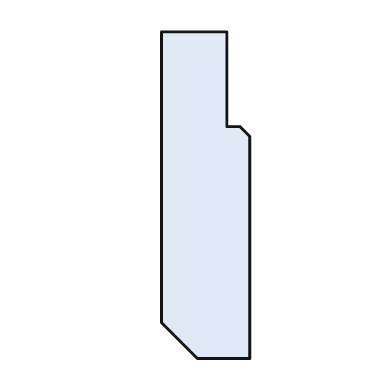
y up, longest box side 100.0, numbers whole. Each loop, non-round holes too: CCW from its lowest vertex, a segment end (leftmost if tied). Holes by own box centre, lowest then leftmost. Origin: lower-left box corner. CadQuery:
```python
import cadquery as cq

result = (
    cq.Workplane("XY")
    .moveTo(11.0, 0.0)
    .lineTo(27.0, 0.0)
    .lineTo(27.0, 68.0)
    .lineTo(24.0, 71.0)
    .lineTo(20.0, 71.0)
    .lineTo(20.0, 100.0)
    .lineTo(0.0, 100.0)
    .lineTo(0.0, 11.0)
    .close()
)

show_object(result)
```